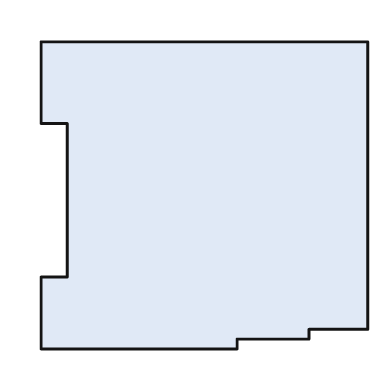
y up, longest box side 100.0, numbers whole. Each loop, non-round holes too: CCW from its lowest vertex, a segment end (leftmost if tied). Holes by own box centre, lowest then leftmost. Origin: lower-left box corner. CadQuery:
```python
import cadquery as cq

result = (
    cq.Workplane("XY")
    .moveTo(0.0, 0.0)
    .lineTo(60.0, 0.0)
    .lineTo(60.0, 3.0)
    .lineTo(82.0, 3.0)
    .lineTo(82.0, 6.0)
    .lineTo(100.0, 6.0)
    .lineTo(100.0, 94.0)
    .lineTo(0.0, 94.0)
    .lineTo(0.0, 69.0)
    .lineTo(8.0, 69.0)
    .lineTo(8.0, 22.0)
    .lineTo(0.0, 22.0)
    .close()
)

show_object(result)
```